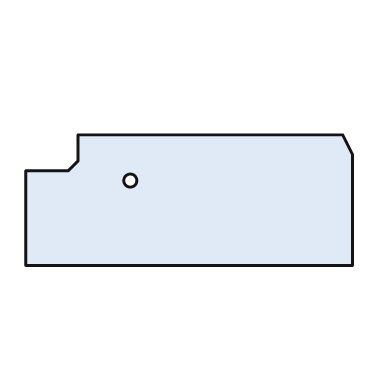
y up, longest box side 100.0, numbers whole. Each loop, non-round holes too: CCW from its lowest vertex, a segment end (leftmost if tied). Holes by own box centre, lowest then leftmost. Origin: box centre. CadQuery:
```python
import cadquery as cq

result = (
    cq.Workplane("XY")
    .moveTo(-50.0, -20.0)
    .lineTo(50.0, -20.0)
    .lineTo(50.0, 14.0)
    .lineTo(47.0, 20.0)
    .lineTo(-34.0, 20.0)
    .lineTo(-34.0, 12.0)
    .lineTo(-37.0, 9.0)
    .lineTo(-50.0, 9.0)
    .close()
    .moveTo(-18.0, 6.0)
    .circle(2.0)
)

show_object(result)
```